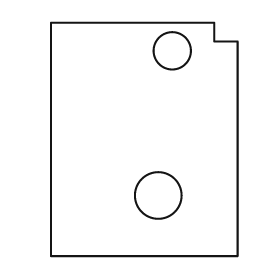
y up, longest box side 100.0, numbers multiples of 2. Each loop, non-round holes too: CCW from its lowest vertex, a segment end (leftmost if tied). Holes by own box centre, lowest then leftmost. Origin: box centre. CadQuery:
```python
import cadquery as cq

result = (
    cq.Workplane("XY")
    .moveTo(-40.0, -50.0)
    .lineTo(40.0, -50.0)
    .lineTo(40.0, 42.0)
    .lineTo(30.0, 42.0)
    .lineTo(30.0, 50.0)
    .lineTo(-40.0, 50.0)
    .close()
    .moveTo(6.0, -24.0)
    .circle(10.0)
    .moveTo(12.0, 38.0)
    .circle(8.0)
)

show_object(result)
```